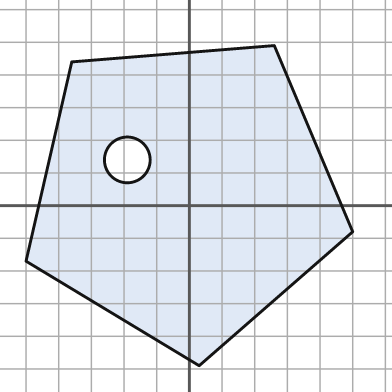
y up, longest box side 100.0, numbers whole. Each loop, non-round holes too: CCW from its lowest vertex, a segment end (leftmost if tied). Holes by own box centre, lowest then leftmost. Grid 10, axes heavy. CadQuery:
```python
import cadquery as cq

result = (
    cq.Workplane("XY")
    .moveTo(3.0, -49.0)
    .lineTo(50.0, -8.0)
    .lineTo(26.0, 49.0)
    .lineTo(-36.0, 44.0)
    .lineTo(-50.0, -17.0)
    .close()
    .moveTo(-19.0, 14.0)
    .circle(7.0)
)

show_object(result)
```